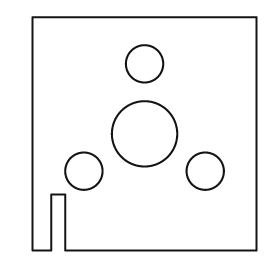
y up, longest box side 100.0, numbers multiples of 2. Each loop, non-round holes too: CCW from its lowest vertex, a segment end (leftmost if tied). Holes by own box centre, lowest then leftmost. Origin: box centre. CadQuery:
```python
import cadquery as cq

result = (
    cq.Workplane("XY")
    .moveTo(-48.0, -50.0)
    .lineTo(-40.0, -50.0)
    .lineTo(-40.0, -26.0)
    .lineTo(-34.0, -26.0)
    .lineTo(-34.0, -50.0)
    .lineTo(48.0, -50.0)
    .lineTo(48.0, 50.0)
    .lineTo(-48.0, 50.0)
    .close()
    .moveTo(-26.0, -16.0)
    .circle(8.0)
    .moveTo(26.0, -16.0)
    .circle(8.0)
    .moveTo(0.0, 0.0)
    .circle(14.0)
    .moveTo(0.0, 30.0)
    .circle(8.0)
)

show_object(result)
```